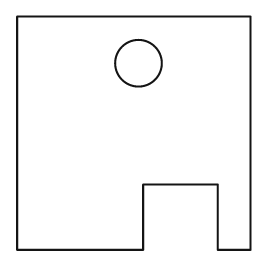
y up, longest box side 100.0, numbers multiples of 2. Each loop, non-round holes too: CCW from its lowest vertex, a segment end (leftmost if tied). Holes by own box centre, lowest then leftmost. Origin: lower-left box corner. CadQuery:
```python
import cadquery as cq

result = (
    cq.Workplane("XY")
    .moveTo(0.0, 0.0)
    .lineTo(54.0, 0.0)
    .lineTo(54.0, 28.0)
    .lineTo(86.0, 28.0)
    .lineTo(86.0, 0.0)
    .lineTo(100.0, 0.0)
    .lineTo(100.0, 100.0)
    .lineTo(0.0, 100.0)
    .close()
    .moveTo(52.0, 80.0)
    .circle(10.0)
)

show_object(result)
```